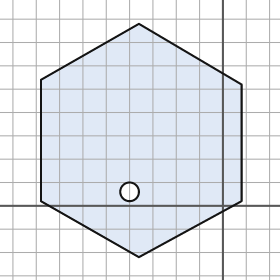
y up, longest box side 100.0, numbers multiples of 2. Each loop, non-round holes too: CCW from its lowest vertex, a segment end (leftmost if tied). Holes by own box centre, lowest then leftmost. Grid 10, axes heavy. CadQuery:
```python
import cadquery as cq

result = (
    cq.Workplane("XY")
    .moveTo(-36.0, -22.0)
    .lineTo(8.0, 2.0)
    .lineTo(8.0, 52.0)
    .lineTo(-36.0, 78.0)
    .lineTo(-78.0, 54.0)
    .lineTo(-78.0, 2.0)
    .close()
    .moveTo(-40.0, 6.0)
    .circle(4.0)
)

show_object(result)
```